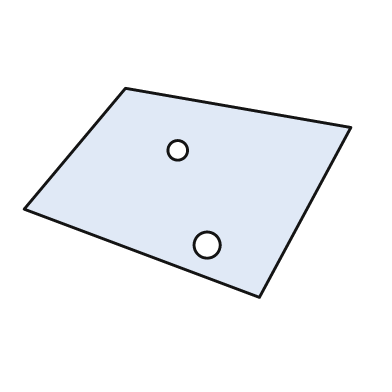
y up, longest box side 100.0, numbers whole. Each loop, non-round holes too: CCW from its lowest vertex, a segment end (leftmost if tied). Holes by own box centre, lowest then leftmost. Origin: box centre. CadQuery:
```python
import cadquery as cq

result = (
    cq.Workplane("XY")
    .moveTo(22.0, -32.0)
    .lineTo(50.0, 20.0)
    .lineTo(-19.0, 32.0)
    .lineTo(-50.0, -5.0)
    .close()
    .moveTo(6.0, -16.0)
    .circle(4.0)
    .moveTo(-3.0, 13.0)
    .circle(3.0)
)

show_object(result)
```